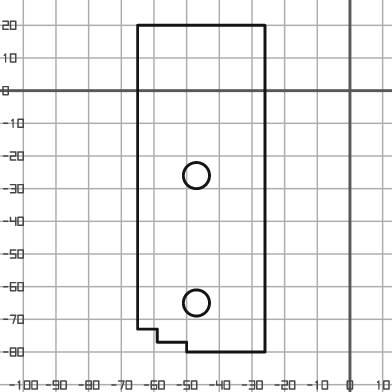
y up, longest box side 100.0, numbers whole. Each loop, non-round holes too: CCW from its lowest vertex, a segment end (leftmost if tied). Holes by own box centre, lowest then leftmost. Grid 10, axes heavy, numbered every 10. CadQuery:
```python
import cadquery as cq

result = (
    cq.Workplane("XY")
    .moveTo(-50.0, -80.0)
    .lineTo(-26.0, -80.0)
    .lineTo(-26.0, 20.0)
    .lineTo(-65.0, 20.0)
    .lineTo(-65.0, -73.0)
    .lineTo(-59.0, -73.0)
    .lineTo(-59.0, -77.0)
    .lineTo(-50.0, -77.0)
    .close()
    .moveTo(-47.0, -65.0)
    .circle(4.0)
    .moveTo(-47.0, -26.0)
    .circle(4.0)
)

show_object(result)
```